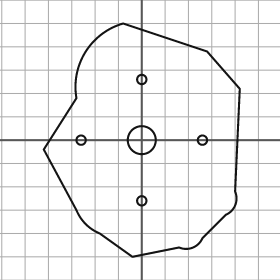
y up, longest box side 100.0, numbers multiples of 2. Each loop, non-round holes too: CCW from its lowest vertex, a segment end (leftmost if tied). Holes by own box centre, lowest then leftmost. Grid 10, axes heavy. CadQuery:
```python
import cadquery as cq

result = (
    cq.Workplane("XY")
    .moveTo(-4.0, -50.0)
    .lineTo(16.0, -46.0)
    .threePointArc((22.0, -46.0), (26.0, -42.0))
    .lineTo(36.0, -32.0)
    .threePointArc((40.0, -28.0), (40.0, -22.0))
    .lineTo(42.0, 22.0)
    .lineTo(28.0, 38.0)
    .lineTo(-8.0, 50.0)
    .threePointArc((-24.0, 38.0), (-28.0, 18.0))
    .lineTo(-42.0, -4.0)
    .lineTo(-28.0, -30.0)
    .threePointArc((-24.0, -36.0), (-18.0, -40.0))
    .close()
    .moveTo(0.0, -26.0)
    .circle(2.0)
    .moveTo(-26.0, 0.0)
    .circle(2.0)
    .moveTo(0.0, 0.0)
    .circle(6.0)
    .moveTo(26.0, 0.0)
    .circle(2.0)
    .moveTo(0.0, 26.0)
    .circle(2.0)
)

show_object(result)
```